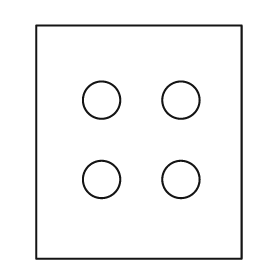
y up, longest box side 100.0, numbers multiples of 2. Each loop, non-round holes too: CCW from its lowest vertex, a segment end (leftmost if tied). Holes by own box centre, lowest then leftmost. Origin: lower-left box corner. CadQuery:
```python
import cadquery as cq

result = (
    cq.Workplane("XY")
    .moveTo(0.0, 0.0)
    .lineTo(88.0, 0.0)
    .lineTo(88.0, 100.0)
    .lineTo(0.0, 100.0)
    .close()
    .moveTo(28.0, 34.0)
    .circle(8.0)
    .moveTo(62.0, 34.0)
    .circle(8.0)
    .moveTo(28.0, 68.0)
    .circle(8.0)
    .moveTo(62.0, 68.0)
    .circle(8.0)
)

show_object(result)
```